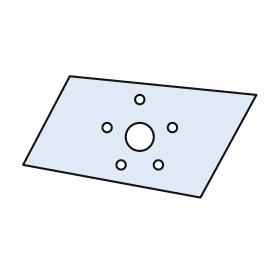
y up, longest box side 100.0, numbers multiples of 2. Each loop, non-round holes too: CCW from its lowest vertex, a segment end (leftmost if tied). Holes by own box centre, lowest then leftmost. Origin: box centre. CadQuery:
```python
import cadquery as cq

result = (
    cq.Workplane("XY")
    .moveTo(26.0, -26.0)
    .lineTo(50.0, 18.0)
    .lineTo(-30.0, 26.0)
    .lineTo(-50.0, -12.0)
    .close()
    .moveTo(-8.0, -12.0)
    .circle(2.0)
    .moveTo(8.0, -12.0)
    .circle(2.0)
    .moveTo(0.0, 0.0)
    .circle(6.0)
    .moveTo(-14.0, 4.0)
    .circle(2.0)
    .moveTo(14.0, 4.0)
    .circle(2.0)
    .moveTo(0.0, 16.0)
    .circle(2.0)
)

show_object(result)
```